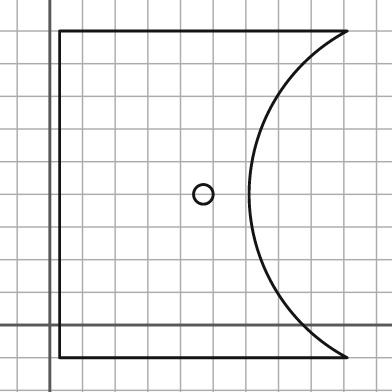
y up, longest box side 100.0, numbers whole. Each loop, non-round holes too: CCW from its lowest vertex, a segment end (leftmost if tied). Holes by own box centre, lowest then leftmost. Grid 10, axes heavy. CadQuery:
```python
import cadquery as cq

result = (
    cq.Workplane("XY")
    .moveTo(3.0, -10.0)
    .lineTo(91.0, -10.0)
    .threePointArc((61.0, 40.0), (91.0, 90.0))
    .lineTo(3.0, 90.0)
    .close()
    .moveTo(47.0, 40.0)
    .circle(3.0)
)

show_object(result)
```